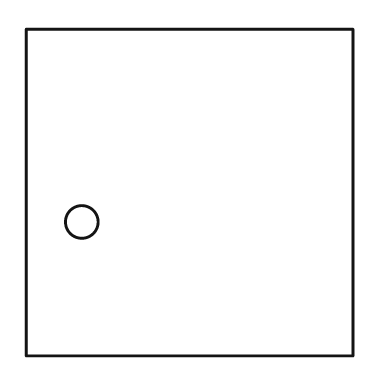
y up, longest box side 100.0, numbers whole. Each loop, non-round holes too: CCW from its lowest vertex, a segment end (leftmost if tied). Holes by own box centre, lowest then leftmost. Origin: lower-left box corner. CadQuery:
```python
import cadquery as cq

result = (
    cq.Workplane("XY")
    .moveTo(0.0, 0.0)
    .lineTo(100.0, 0.0)
    .lineTo(100.0, 100.0)
    .lineTo(0.0, 100.0)
    .close()
    .moveTo(17.0, 41.0)
    .circle(5.0)
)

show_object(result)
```